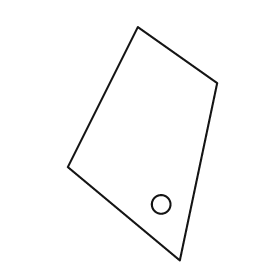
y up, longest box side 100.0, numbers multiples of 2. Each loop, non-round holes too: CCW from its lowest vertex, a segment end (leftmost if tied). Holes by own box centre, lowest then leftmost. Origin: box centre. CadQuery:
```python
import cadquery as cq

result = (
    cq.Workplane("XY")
    .moveTo(16.0, -50.0)
    .lineTo(32.0, 26.0)
    .lineTo(-2.0, 50.0)
    .lineTo(-32.0, -10.0)
    .close()
    .moveTo(8.0, -26.0)
    .circle(4.0)
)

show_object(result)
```